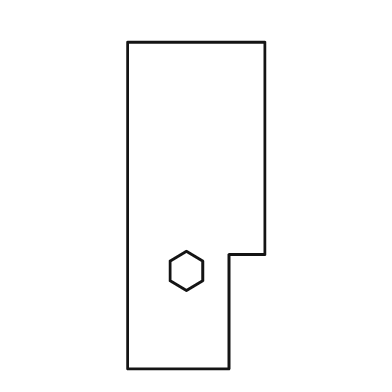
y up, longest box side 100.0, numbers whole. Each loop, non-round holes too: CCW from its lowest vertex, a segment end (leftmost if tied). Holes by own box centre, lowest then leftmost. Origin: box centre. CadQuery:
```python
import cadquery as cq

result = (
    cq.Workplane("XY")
    .moveTo(-21.0, -50.0)
    .lineTo(10.0, -50.0)
    .lineTo(10.0, -15.0)
    .lineTo(21.0, -15.0)
    .lineTo(21.0, 50.0)
    .lineTo(-21.0, 50.0)
    .close()
    .moveTo(-3.0, -26.0)
    .lineTo(2.0, -23.0)
    .lineTo(2.0, -17.0)
    .lineTo(-3.0, -14.0)
    .lineTo(-8.0, -17.0)
    .lineTo(-8.0, -23.0)
    .close()
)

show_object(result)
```